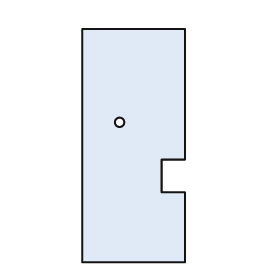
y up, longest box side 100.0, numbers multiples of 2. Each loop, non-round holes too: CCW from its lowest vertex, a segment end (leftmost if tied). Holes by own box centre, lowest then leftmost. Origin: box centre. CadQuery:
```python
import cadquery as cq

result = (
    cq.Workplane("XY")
    .moveTo(-22.0, -50.0)
    .lineTo(22.0, -50.0)
    .lineTo(22.0, -20.0)
    .lineTo(12.0, -20.0)
    .lineTo(12.0, -6.0)
    .lineTo(22.0, -6.0)
    .lineTo(22.0, 50.0)
    .lineTo(-22.0, 50.0)
    .close()
    .moveTo(-6.0, 10.0)
    .circle(2.0)
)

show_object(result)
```